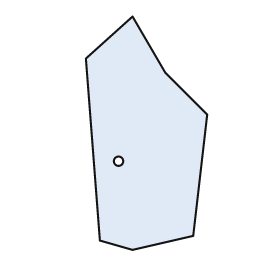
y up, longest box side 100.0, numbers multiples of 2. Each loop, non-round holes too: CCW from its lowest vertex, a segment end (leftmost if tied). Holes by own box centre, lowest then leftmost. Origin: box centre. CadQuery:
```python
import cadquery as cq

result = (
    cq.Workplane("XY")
    .moveTo(-6.0, -50.0)
    .lineTo(20.0, -44.0)
    .lineTo(26.0, 8.0)
    .lineTo(8.0, 26.0)
    .lineTo(-6.0, 50.0)
    .lineTo(-26.0, 32.0)
    .lineTo(-20.0, -46.0)
    .close()
    .moveTo(-12.0, -12.0)
    .circle(2.0)
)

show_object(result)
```